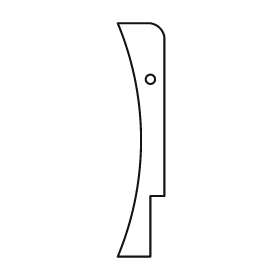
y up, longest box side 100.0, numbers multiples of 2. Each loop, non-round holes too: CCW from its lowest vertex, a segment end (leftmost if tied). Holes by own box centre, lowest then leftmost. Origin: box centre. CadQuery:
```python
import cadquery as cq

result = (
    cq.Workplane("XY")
    .moveTo(-10.0, -50.0)
    .lineTo(4.0, -50.0)
    .lineTo(4.0, -24.0)
    .lineTo(10.0, -24.0)
    .lineTo(10.0, 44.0)
    .threePointArc((8.0, 48.0), (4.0, 50.0))
    .lineTo(-10.0, 50.0)
    .threePointArc((0.0, 0.0), (-10.0, -50.0))
    .close()
    .moveTo(4.0, 26.0)
    .circle(2.0)
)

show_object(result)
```